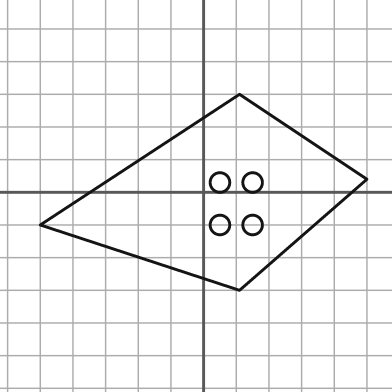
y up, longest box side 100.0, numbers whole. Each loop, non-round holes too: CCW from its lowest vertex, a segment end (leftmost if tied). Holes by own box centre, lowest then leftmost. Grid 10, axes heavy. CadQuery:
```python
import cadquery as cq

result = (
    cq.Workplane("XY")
    .moveTo(11.0, -30.0)
    .lineTo(50.0, 4.0)
    .lineTo(11.0, 30.0)
    .lineTo(-50.0, -10.0)
    .close()
    .moveTo(5.0, -10.0)
    .circle(3.0)
    .moveTo(15.0, -10.0)
    .circle(3.0)
    .moveTo(5.0, 3.0)
    .circle(3.0)
    .moveTo(15.0, 3.0)
    .circle(3.0)
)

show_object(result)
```